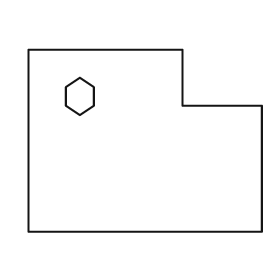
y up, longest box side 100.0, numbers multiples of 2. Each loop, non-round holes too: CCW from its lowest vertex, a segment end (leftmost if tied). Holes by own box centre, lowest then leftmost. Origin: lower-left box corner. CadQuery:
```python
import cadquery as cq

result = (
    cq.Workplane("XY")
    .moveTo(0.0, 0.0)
    .lineTo(100.0, 0.0)
    .lineTo(100.0, 54.0)
    .lineTo(66.0, 54.0)
    .lineTo(66.0, 78.0)
    .lineTo(0.0, 78.0)
    .close()
    .moveTo(22.0, 50.0)
    .lineTo(28.0, 54.0)
    .lineTo(28.0, 62.0)
    .lineTo(22.0, 66.0)
    .lineTo(16.0, 62.0)
    .lineTo(16.0, 54.0)
    .close()
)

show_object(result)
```